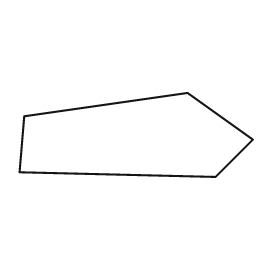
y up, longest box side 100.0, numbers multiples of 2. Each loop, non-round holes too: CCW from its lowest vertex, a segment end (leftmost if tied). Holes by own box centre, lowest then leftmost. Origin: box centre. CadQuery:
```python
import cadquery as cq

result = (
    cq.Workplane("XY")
    .moveTo(34.0, -18.0)
    .lineTo(50.0, -2.0)
    .lineTo(22.0, 18.0)
    .lineTo(-48.0, 8.0)
    .lineTo(-50.0, -16.0)
    .close()
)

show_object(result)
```